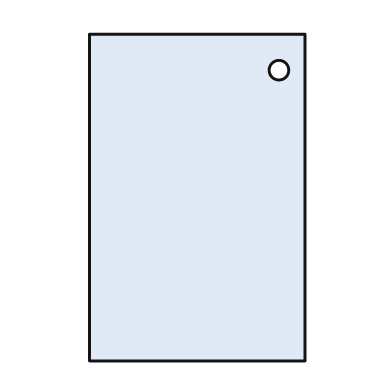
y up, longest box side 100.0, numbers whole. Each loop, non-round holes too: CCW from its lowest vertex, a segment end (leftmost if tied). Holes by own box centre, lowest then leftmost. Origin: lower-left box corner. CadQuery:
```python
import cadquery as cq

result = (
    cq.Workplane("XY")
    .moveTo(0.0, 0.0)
    .lineTo(66.0, 0.0)
    .lineTo(66.0, 100.0)
    .lineTo(0.0, 100.0)
    .close()
    .moveTo(58.0, 89.0)
    .circle(3.0)
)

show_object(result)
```